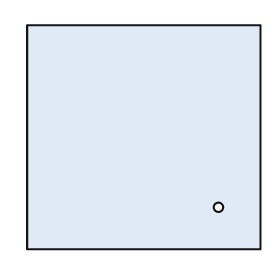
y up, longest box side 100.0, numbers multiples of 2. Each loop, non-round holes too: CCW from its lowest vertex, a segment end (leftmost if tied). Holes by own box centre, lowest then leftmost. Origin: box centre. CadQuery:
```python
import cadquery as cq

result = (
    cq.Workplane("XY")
    .moveTo(-50.0, -48.0)
    .lineTo(50.0, -48.0)
    .lineTo(50.0, 48.0)
    .lineTo(-50.0, 48.0)
    .close()
    .moveTo(32.0, -30.0)
    .circle(2.0)
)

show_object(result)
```